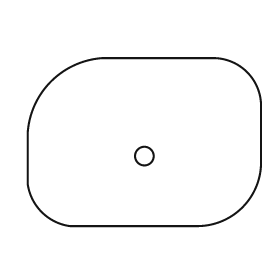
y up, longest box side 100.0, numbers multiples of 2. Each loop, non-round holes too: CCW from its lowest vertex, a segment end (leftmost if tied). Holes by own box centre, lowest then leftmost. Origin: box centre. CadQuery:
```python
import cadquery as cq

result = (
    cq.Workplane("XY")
    .moveTo(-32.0, -36.0)
    .lineTo(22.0, -36.0)
    .threePointArc((42.0, -28.0), (50.0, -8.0))
    .lineTo(50.0, 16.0)
    .threePointArc((44.0, 30.0), (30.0, 36.0))
    .lineTo(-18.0, 36.0)
    .threePointArc((-40.0, 26.0), (-50.0, 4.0))
    .lineTo(-50.0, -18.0)
    .threePointArc((-44.0, -30.0), (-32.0, -36.0))
    .close()
    .moveTo(0.0, -6.0)
    .circle(4.0)
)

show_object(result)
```